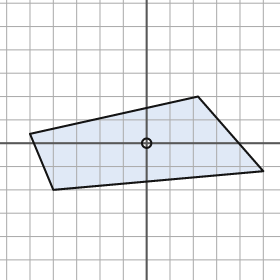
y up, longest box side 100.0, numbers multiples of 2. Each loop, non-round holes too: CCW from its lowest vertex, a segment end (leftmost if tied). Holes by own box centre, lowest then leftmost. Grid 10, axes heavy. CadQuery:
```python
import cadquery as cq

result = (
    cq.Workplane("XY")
    .moveTo(-40.0, -20.0)
    .lineTo(50.0, -12.0)
    .lineTo(22.0, 20.0)
    .lineTo(-50.0, 4.0)
    .close()
    .moveTo(0.0, 0.0)
    .circle(2.0)
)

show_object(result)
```